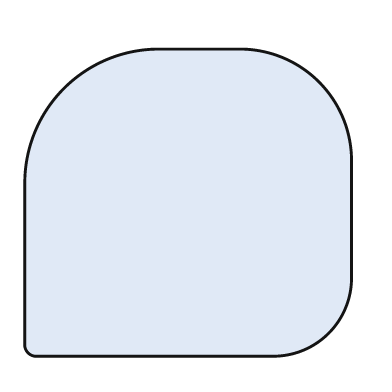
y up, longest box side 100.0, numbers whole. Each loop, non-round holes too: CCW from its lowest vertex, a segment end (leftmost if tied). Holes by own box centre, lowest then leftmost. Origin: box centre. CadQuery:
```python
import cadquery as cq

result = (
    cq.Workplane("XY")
    .moveTo(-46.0, -47.0)
    .lineTo(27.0, -47.0)
    .threePointArc((43.0, -40.0), (50.0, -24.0))
    .lineTo(50.0, 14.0)
    .threePointArc((40.0, 37.0), (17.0, 47.0))
    .lineTo(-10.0, 47.0)
    .threePointArc((-38.0, 35.0), (-50.0, 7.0))
    .lineTo(-50.0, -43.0)
    .threePointArc((-49.0, -46.0), (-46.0, -47.0))
    .close()
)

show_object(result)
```